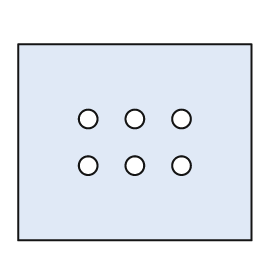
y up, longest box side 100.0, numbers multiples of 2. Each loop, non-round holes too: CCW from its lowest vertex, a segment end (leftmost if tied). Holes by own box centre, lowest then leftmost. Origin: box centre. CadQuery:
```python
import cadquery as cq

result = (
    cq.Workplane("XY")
    .moveTo(-50.0, -42.0)
    .lineTo(50.0, -42.0)
    .lineTo(50.0, 42.0)
    .lineTo(-50.0, 42.0)
    .close()
    .moveTo(-20.0, -10.0)
    .circle(4.0)
    .moveTo(0.0, -10.0)
    .circle(4.0)
    .moveTo(20.0, -10.0)
    .circle(4.0)
    .moveTo(-20.0, 10.0)
    .circle(4.0)
    .moveTo(0.0, 10.0)
    .circle(4.0)
    .moveTo(20.0, 10.0)
    .circle(4.0)
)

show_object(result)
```